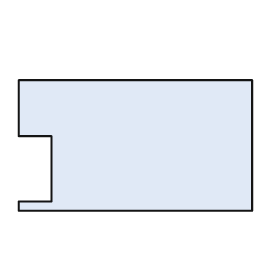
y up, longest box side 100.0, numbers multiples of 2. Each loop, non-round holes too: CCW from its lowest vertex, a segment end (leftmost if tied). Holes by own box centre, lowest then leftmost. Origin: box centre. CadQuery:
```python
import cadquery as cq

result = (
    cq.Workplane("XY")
    .moveTo(-50.0, -28.0)
    .lineTo(50.0, -28.0)
    .lineTo(50.0, 28.0)
    .lineTo(-50.0, 28.0)
    .lineTo(-50.0, 4.0)
    .lineTo(-36.0, 4.0)
    .lineTo(-36.0, -24.0)
    .lineTo(-50.0, -24.0)
    .close()
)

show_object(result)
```